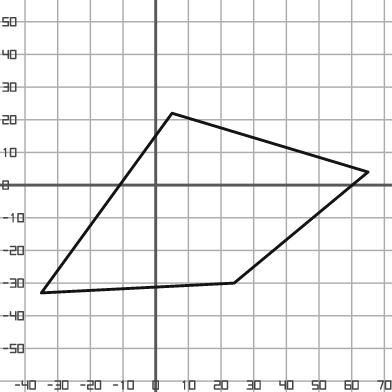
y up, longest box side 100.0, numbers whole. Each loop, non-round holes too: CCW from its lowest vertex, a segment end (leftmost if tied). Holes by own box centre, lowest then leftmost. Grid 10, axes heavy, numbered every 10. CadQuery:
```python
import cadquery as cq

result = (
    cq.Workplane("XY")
    .moveTo(-35.0, -33.0)
    .lineTo(24.0, -30.0)
    .lineTo(65.0, 4.0)
    .lineTo(5.0, 22.0)
    .close()
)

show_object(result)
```